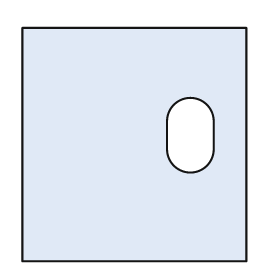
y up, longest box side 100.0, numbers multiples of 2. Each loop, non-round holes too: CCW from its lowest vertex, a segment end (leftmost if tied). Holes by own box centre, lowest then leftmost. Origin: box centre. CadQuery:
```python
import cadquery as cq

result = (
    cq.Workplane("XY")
    .moveTo(-48.0, -50.0)
    .lineTo(48.0, -50.0)
    .lineTo(48.0, 50.0)
    .lineTo(-48.0, 50.0)
    .close()
    .moveTo(14.0, -2.0)
    .threePointArc((24.0, -12.0), (34.0, -2.0))
    .lineTo(34.0, 10.0)
    .threePointArc((24.0, 20.0), (14.0, 10.0))
    .close()
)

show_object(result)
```